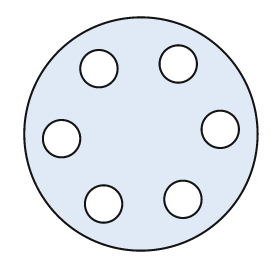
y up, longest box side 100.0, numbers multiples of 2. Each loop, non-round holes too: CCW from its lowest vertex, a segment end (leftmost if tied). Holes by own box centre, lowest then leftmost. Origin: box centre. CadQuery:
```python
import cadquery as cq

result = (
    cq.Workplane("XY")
    .moveTo(0.0, 0.0)
    .circle(50.0)
    .moveTo(-16.0, -30.0)
    .circle(8.0)
    .moveTo(18.0, -28.0)
    .circle(8.0)
    .moveTo(-34.0, -2.0)
    .circle(8.0)
    .moveTo(34.0, 2.0)
    .circle(8.0)
    .moveTo(-18.0, 28.0)
    .circle(8.0)
    .moveTo(16.0, 30.0)
    .circle(8.0)
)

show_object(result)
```